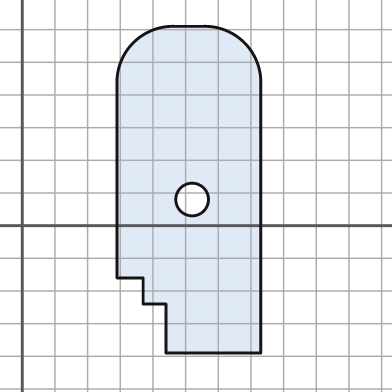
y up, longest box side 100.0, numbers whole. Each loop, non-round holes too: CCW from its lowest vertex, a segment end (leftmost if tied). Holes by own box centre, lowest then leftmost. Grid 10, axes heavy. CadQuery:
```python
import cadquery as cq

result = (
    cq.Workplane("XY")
    .moveTo(44.0, -39.0)
    .lineTo(73.0, -39.0)
    .lineTo(73.0, 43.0)
    .threePointArc((68.0, 56.0), (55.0, 61.0))
    .lineTo(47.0, 61.0)
    .threePointArc((34.0, 56.0), (29.0, 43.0))
    .lineTo(29.0, -16.0)
    .lineTo(37.0, -16.0)
    .lineTo(37.0, -24.0)
    .lineTo(44.0, -24.0)
    .close()
    .moveTo(52.0, 8.0)
    .circle(5.0)
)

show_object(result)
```